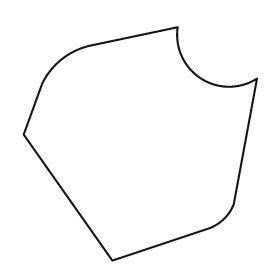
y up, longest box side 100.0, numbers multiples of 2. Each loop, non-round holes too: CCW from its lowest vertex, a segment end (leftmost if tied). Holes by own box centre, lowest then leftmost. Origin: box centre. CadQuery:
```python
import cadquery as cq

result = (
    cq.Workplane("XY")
    .moveTo(-12.0, -50.0)
    .lineTo(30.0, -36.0)
    .threePointArc((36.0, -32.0), (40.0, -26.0))
    .lineTo(50.0, 28.0)
    .threePointArc((26.0, 28.0), (16.0, 50.0))
    .lineTo(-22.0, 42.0)
    .threePointArc((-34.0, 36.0), (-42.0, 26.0))
    .lineTo(-50.0, 4.0)
    .close()
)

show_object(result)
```